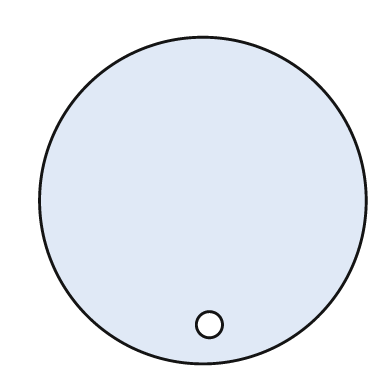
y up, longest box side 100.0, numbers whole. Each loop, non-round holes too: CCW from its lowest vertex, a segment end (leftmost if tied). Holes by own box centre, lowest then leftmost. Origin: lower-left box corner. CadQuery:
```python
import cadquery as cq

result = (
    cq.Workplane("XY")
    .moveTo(50.0, 50.0)
    .circle(50.0)
    .moveTo(52.0, 12.0)
    .circle(4.0)
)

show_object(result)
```